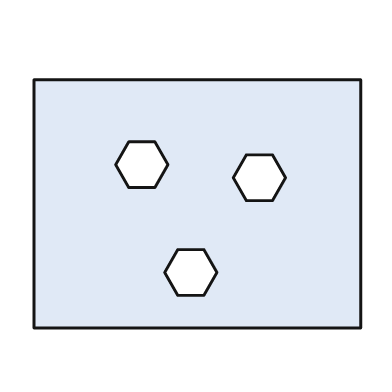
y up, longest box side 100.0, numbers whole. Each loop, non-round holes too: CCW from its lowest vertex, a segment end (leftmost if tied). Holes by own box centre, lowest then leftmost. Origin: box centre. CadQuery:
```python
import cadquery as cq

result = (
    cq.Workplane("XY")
    .moveTo(-50.0, -38.0)
    .lineTo(50.0, -38.0)
    .lineTo(50.0, 38.0)
    .lineTo(-50.0, 38.0)
    .close()
    .moveTo(-6.0, -28.0)
    .lineTo(2.0, -28.0)
    .lineTo(6.0, -21.0)
    .lineTo(2.0, -14.0)
    .lineTo(-6.0, -14.0)
    .lineTo(-10.0, -21.0)
    .close()
    .moveTo(15.0, 1.0)
    .lineTo(23.0, 1.0)
    .lineTo(27.0, 8.0)
    .lineTo(23.0, 15.0)
    .lineTo(15.0, 15.0)
    .lineTo(11.0, 8.0)
    .close()
    .moveTo(-21.0, 5.0)
    .lineTo(-13.0, 5.0)
    .lineTo(-9.0, 12.0)
    .lineTo(-13.0, 19.0)
    .lineTo(-21.0, 19.0)
    .lineTo(-25.0, 12.0)
    .close()
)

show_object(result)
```